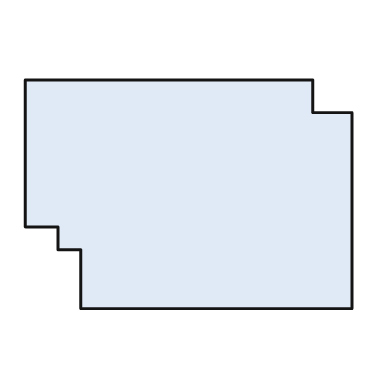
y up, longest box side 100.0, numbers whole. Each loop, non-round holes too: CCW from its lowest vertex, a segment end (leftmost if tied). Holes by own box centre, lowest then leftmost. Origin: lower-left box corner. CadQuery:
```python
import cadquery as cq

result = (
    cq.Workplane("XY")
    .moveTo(17.0, 0.0)
    .lineTo(100.0, 0.0)
    .lineTo(100.0, 60.0)
    .lineTo(88.0, 60.0)
    .lineTo(88.0, 70.0)
    .lineTo(0.0, 70.0)
    .lineTo(0.0, 25.0)
    .lineTo(10.0, 25.0)
    .lineTo(10.0, 18.0)
    .lineTo(17.0, 18.0)
    .close()
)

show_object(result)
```